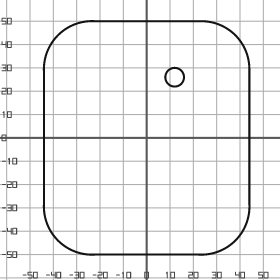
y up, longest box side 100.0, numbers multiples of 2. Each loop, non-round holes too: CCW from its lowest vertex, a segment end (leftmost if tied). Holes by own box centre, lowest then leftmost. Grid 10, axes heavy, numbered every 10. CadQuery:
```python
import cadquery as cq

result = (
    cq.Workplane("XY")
    .moveTo(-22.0, -50.0)
    .lineTo(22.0, -50.0)
    .threePointArc((38.0, -44.0), (44.0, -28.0))
    .lineTo(44.0, 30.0)
    .threePointArc((38.0, 44.0), (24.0, 50.0))
    .lineTo(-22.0, 50.0)
    .threePointArc((-38.0, 44.0), (-44.0, 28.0))
    .lineTo(-44.0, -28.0)
    .threePointArc((-38.0, -44.0), (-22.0, -50.0))
    .close()
    .moveTo(12.0, 26.0)
    .circle(4.0)
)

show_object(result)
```